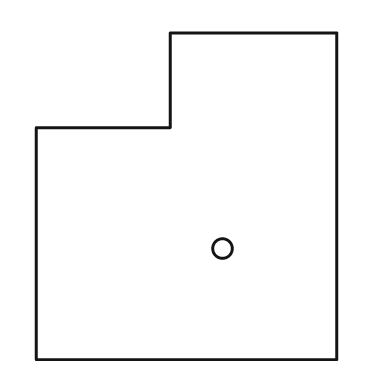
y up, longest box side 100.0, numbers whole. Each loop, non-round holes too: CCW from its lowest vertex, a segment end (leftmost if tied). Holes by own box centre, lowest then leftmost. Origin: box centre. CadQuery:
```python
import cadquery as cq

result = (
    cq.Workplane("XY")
    .moveTo(-46.0, -50.0)
    .lineTo(46.0, -50.0)
    .lineTo(46.0, 50.0)
    .lineTo(-5.0, 50.0)
    .lineTo(-5.0, 21.0)
    .lineTo(-46.0, 21.0)
    .close()
    .moveTo(11.0, -16.0)
    .circle(3.0)
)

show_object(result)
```